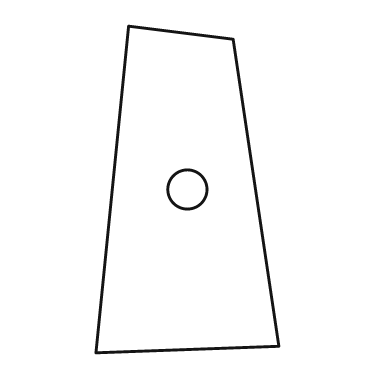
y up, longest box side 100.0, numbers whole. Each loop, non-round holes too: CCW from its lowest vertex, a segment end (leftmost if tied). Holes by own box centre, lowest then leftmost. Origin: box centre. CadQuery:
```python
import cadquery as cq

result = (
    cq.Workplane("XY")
    .moveTo(-28.0, -50.0)
    .lineTo(28.0, -48.0)
    .lineTo(14.0, 46.0)
    .lineTo(-18.0, 50.0)
    .close()
    .moveTo(0.0, 0.0)
    .circle(6.0)
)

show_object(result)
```